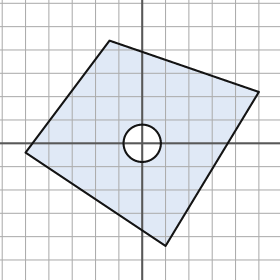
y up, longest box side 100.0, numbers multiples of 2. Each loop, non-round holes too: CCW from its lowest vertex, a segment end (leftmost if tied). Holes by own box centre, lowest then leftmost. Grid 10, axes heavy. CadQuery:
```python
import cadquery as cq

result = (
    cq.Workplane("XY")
    .moveTo(10.0, -44.0)
    .lineTo(50.0, 22.0)
    .lineTo(-14.0, 44.0)
    .lineTo(-50.0, -4.0)
    .close()
    .moveTo(0.0, 0.0)
    .circle(8.0)
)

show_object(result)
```